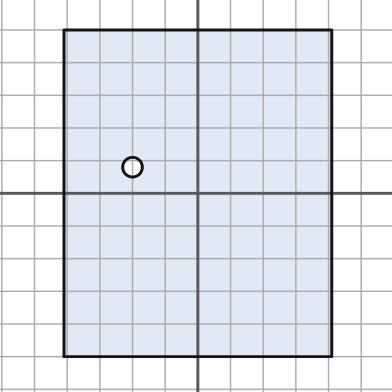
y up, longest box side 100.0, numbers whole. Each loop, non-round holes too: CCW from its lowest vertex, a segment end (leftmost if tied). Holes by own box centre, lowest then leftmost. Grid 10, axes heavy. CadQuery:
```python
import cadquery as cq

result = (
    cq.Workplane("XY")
    .moveTo(-41.0, -50.0)
    .lineTo(41.0, -50.0)
    .lineTo(41.0, 50.0)
    .lineTo(-41.0, 50.0)
    .close()
    .moveTo(-20.0, 8.0)
    .circle(3.0)
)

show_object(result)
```